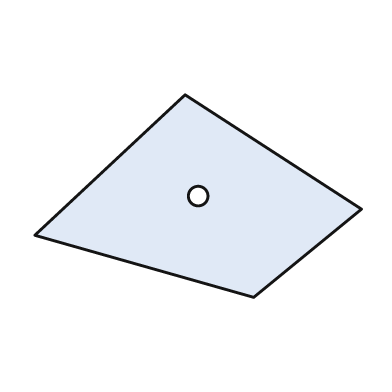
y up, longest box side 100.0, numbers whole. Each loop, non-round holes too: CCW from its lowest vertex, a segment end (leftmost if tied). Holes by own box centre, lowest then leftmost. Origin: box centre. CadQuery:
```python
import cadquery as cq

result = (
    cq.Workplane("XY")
    .moveTo(17.0, -31.0)
    .lineTo(50.0, -4.0)
    .lineTo(-4.0, 31.0)
    .lineTo(-50.0, -12.0)
    .close()
    .moveTo(0.0, 0.0)
    .circle(3.0)
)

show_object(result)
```